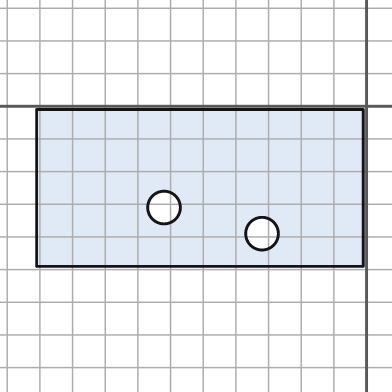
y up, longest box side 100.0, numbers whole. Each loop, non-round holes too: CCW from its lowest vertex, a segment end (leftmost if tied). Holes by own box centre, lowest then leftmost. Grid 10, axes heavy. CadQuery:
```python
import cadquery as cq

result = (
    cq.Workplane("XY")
    .moveTo(-101.0, -49.0)
    .lineTo(-1.0, -49.0)
    .lineTo(-1.0, -1.0)
    .lineTo(-101.0, -1.0)
    .close()
    .moveTo(-32.0, -39.0)
    .circle(5.0)
    .moveTo(-62.0, -31.0)
    .circle(5.0)
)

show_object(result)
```